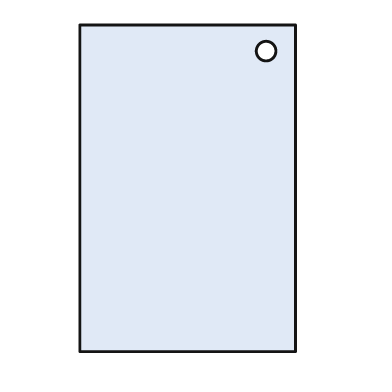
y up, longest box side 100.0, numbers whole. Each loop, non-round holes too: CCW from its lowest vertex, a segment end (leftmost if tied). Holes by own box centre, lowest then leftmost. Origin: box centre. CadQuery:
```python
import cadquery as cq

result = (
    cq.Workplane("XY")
    .moveTo(-33.0, -50.0)
    .lineTo(33.0, -50.0)
    .lineTo(33.0, 50.0)
    .lineTo(-33.0, 50.0)
    .close()
    .moveTo(24.0, 42.0)
    .circle(3.0)
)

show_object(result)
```